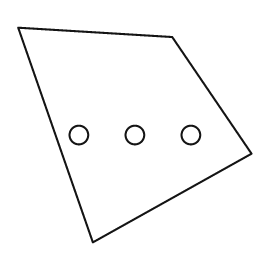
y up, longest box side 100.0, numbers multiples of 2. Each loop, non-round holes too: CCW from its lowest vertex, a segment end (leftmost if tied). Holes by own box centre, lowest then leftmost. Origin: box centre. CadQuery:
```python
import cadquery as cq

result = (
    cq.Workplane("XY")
    .moveTo(-18.0, -46.0)
    .lineTo(50.0, -8.0)
    .lineTo(16.0, 42.0)
    .lineTo(-50.0, 46.0)
    .close()
    .moveTo(-24.0, 0.0)
    .circle(4.0)
    .moveTo(0.0, 0.0)
    .circle(4.0)
    .moveTo(24.0, 0.0)
    .circle(4.0)
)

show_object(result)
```